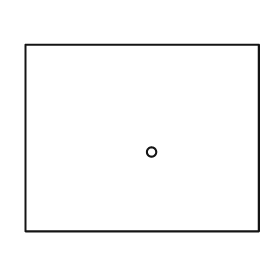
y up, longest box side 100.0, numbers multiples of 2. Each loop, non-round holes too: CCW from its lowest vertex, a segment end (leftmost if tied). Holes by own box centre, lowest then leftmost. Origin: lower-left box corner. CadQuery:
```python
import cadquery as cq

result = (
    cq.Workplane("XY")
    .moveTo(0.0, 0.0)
    .lineTo(100.0, 0.0)
    .lineTo(100.0, 80.0)
    .lineTo(0.0, 80.0)
    .close()
    .moveTo(54.0, 34.0)
    .circle(2.0)
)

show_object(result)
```